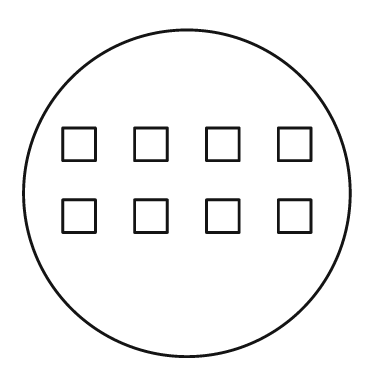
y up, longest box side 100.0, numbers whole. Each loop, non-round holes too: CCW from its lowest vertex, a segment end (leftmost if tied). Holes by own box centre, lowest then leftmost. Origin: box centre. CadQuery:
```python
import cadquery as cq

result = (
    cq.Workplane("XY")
    .moveTo(0.0, 0.0)
    .circle(50.0)
    .moveTo(-38.0, -12.0)
    .lineTo(-28.0, -12.0)
    .lineTo(-28.0, -2.0)
    .lineTo(-38.0, -2.0)
    .close()
    .moveTo(-16.0, -12.0)
    .lineTo(-6.0, -12.0)
    .lineTo(-6.0, -2.0)
    .lineTo(-16.0, -2.0)
    .close()
    .moveTo(6.0, -12.0)
    .lineTo(16.0, -12.0)
    .lineTo(16.0, -2.0)
    .lineTo(6.0, -2.0)
    .close()
    .moveTo(28.0, -12.0)
    .lineTo(38.0, -12.0)
    .lineTo(38.0, -2.0)
    .lineTo(28.0, -2.0)
    .close()
    .moveTo(-38.0, 10.0)
    .lineTo(-28.0, 10.0)
    .lineTo(-28.0, 20.0)
    .lineTo(-38.0, 20.0)
    .close()
    .moveTo(-16.0, 10.0)
    .lineTo(-6.0, 10.0)
    .lineTo(-6.0, 20.0)
    .lineTo(-16.0, 20.0)
    .close()
    .moveTo(6.0, 10.0)
    .lineTo(16.0, 10.0)
    .lineTo(16.0, 20.0)
    .lineTo(6.0, 20.0)
    .close()
    .moveTo(28.0, 10.0)
    .lineTo(38.0, 10.0)
    .lineTo(38.0, 20.0)
    .lineTo(28.0, 20.0)
    .close()
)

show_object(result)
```